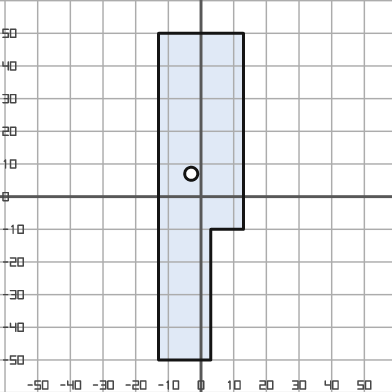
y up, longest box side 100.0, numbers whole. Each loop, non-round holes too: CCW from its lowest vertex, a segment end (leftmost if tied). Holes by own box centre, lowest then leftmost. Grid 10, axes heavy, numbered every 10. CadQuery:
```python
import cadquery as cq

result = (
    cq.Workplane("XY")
    .moveTo(-13.0, -50.0)
    .lineTo(3.0, -50.0)
    .lineTo(3.0, -10.0)
    .lineTo(13.0, -10.0)
    .lineTo(13.0, 50.0)
    .lineTo(-13.0, 50.0)
    .close()
    .moveTo(-3.0, 7.0)
    .circle(2.0)
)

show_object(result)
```